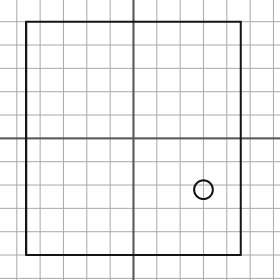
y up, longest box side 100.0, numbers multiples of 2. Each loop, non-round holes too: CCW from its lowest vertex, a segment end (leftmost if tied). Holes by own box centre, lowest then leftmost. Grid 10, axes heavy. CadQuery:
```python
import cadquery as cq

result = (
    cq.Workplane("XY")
    .moveTo(-46.0, -50.0)
    .lineTo(46.0, -50.0)
    .lineTo(46.0, 50.0)
    .lineTo(-46.0, 50.0)
    .close()
    .moveTo(30.0, -22.0)
    .circle(4.0)
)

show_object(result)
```